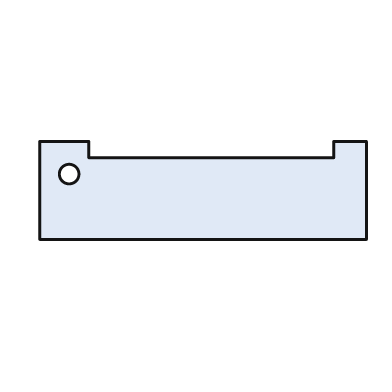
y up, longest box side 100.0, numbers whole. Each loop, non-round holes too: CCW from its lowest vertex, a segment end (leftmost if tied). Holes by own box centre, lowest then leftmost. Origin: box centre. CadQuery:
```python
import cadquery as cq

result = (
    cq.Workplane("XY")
    .moveTo(-50.0, -15.0)
    .lineTo(50.0, -15.0)
    .lineTo(50.0, 15.0)
    .lineTo(40.0, 15.0)
    .lineTo(40.0, 10.0)
    .lineTo(-35.0, 10.0)
    .lineTo(-35.0, 15.0)
    .lineTo(-50.0, 15.0)
    .close()
    .moveTo(-41.0, 5.0)
    .circle(3.0)
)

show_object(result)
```